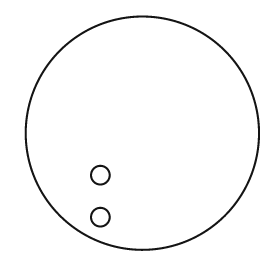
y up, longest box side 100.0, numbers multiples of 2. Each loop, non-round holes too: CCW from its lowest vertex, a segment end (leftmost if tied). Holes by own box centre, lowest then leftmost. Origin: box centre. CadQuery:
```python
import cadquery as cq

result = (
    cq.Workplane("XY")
    .moveTo(0.0, 0.0)
    .circle(50.0)
    .moveTo(-18.0, -36.0)
    .circle(4.0)
    .moveTo(-18.0, -18.0)
    .circle(4.0)
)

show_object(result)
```